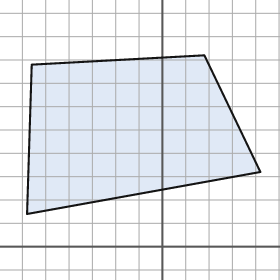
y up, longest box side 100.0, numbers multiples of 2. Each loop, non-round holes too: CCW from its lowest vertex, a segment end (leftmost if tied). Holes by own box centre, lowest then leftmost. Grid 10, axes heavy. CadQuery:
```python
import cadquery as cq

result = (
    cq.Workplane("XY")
    .moveTo(-58.0, 14.0)
    .lineTo(42.0, 32.0)
    .lineTo(18.0, 82.0)
    .lineTo(-56.0, 78.0)
    .close()
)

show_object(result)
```